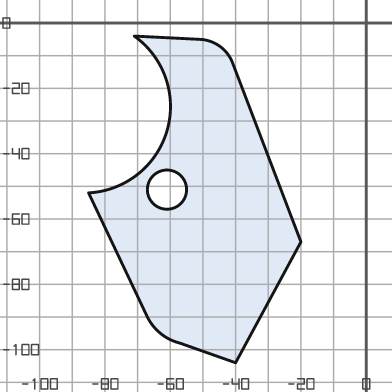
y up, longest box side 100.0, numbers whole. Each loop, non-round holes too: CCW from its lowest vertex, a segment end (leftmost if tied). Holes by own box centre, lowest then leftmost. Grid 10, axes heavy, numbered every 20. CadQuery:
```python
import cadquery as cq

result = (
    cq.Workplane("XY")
    .moveTo(-40.0, -104.0)
    .lineTo(-20.0, -67.0)
    .lineTo(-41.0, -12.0)
    .threePointArc((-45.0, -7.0), (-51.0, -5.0))
    .lineTo(-71.0, -4.0)
    .threePointArc((-61.0, -33.0), (-85.0, -52.0))
    .lineTo(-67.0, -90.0)
    .threePointArc((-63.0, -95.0), (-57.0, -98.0))
    .close()
    .moveTo(-61.0, -51.0)
    .circle(6.0)
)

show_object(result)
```